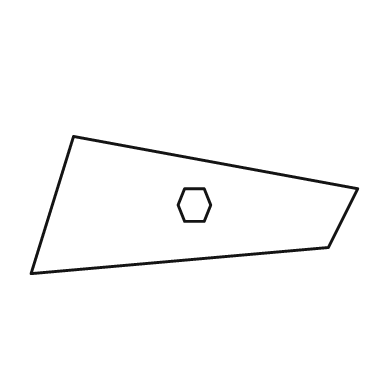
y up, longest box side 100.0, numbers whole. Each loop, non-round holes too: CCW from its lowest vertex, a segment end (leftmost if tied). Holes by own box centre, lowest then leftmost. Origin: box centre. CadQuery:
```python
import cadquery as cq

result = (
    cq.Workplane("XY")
    .moveTo(-50.0, -21.0)
    .lineTo(41.0, -13.0)
    .lineTo(50.0, 5.0)
    .lineTo(-37.0, 21.0)
    .close()
    .moveTo(-3.0, -5.0)
    .lineTo(3.0, -5.0)
    .lineTo(5.0, 0.0)
    .lineTo(3.0, 5.0)
    .lineTo(-3.0, 5.0)
    .lineTo(-5.0, 0.0)
    .close()
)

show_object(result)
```